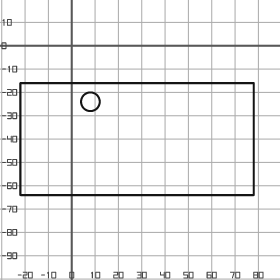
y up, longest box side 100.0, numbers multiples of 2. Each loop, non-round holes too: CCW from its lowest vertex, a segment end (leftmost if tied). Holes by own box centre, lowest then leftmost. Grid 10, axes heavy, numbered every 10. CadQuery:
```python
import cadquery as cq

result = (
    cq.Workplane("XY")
    .moveTo(-22.0, -64.0)
    .lineTo(78.0, -64.0)
    .lineTo(78.0, -16.0)
    .lineTo(-22.0, -16.0)
    .close()
    .moveTo(8.0, -24.0)
    .circle(4.0)
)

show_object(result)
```